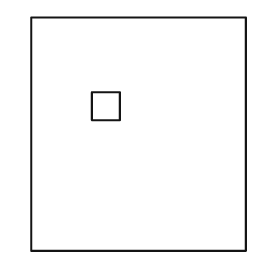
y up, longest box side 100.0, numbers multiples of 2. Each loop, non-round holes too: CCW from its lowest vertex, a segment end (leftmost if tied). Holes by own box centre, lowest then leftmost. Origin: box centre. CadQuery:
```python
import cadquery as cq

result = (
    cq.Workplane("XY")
    .moveTo(-46.0, -50.0)
    .lineTo(46.0, -50.0)
    .lineTo(46.0, 50.0)
    .lineTo(-46.0, 50.0)
    .close()
    .moveTo(-20.0, 6.0)
    .lineTo(-8.0, 6.0)
    .lineTo(-8.0, 18.0)
    .lineTo(-20.0, 18.0)
    .close()
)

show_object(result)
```